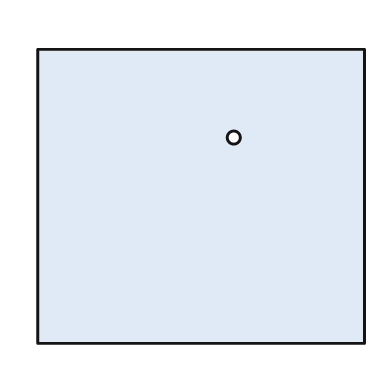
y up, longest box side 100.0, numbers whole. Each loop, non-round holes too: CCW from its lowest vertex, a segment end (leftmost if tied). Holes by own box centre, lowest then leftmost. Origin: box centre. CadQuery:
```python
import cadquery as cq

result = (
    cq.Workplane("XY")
    .moveTo(-50.0, -45.0)
    .lineTo(50.0, -45.0)
    .lineTo(50.0, 45.0)
    .lineTo(-50.0, 45.0)
    .close()
    .moveTo(10.0, 18.0)
    .circle(2.0)
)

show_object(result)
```